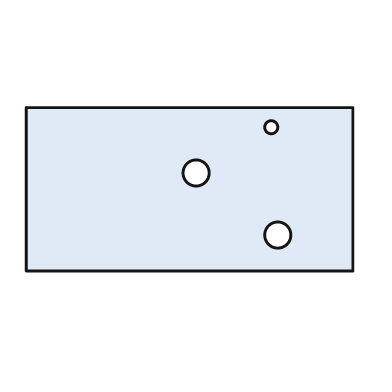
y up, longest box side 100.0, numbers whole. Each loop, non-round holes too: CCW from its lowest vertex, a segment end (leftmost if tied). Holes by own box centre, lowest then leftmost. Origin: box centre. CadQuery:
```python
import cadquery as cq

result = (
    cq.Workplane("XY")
    .moveTo(-50.0, -25.0)
    .lineTo(50.0, -25.0)
    .lineTo(50.0, 25.0)
    .lineTo(-50.0, 25.0)
    .close()
    .moveTo(27.0, -14.0)
    .circle(4.0)
    .moveTo(2.0, 5.0)
    .circle(4.0)
    .moveTo(25.0, 19.0)
    .circle(2.0)
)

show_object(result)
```